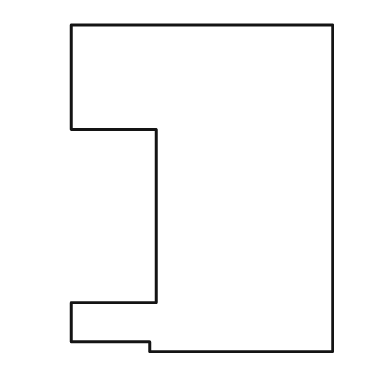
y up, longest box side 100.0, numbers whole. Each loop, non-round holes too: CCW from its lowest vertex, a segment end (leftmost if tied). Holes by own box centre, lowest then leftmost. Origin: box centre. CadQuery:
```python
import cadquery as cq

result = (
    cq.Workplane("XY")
    .moveTo(-16.0, -50.0)
    .lineTo(40.0, -50.0)
    .lineTo(40.0, 50.0)
    .lineTo(-40.0, 50.0)
    .lineTo(-40.0, 18.0)
    .lineTo(-14.0, 18.0)
    .lineTo(-14.0, -35.0)
    .lineTo(-40.0, -35.0)
    .lineTo(-40.0, -47.0)
    .lineTo(-16.0, -47.0)
    .close()
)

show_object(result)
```